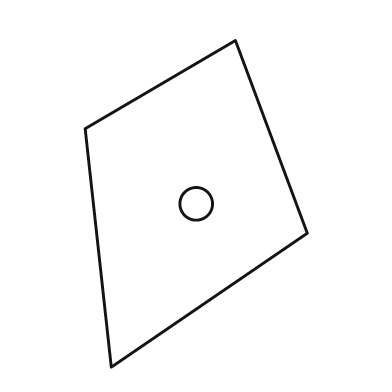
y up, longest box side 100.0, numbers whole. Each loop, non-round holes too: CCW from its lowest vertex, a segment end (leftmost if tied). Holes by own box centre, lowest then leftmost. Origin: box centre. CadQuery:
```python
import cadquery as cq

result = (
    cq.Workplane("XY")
    .moveTo(-26.0, -50.0)
    .lineTo(34.0, -9.0)
    .lineTo(12.0, 50.0)
    .lineTo(-34.0, 23.0)
    .close()
    .moveTo(0.0, 0.0)
    .circle(5.0)
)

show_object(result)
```